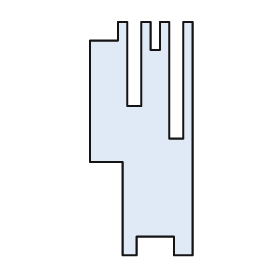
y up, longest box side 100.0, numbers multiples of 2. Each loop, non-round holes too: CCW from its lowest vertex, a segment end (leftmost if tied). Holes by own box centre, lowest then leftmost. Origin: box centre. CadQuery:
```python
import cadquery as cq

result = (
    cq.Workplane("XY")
    .moveTo(-8.0, -50.0)
    .lineTo(-2.0, -50.0)
    .lineTo(-2.0, -42.0)
    .lineTo(14.0, -42.0)
    .lineTo(14.0, -50.0)
    .lineTo(22.0, -50.0)
    .lineTo(22.0, 50.0)
    .lineTo(18.0, 50.0)
    .lineTo(18.0, 0.0)
    .lineTo(12.0, 0.0)
    .lineTo(12.0, 50.0)
    .lineTo(8.0, 50.0)
    .lineTo(8.0, 38.0)
    .lineTo(4.0, 38.0)
    .lineTo(4.0, 50.0)
    .lineTo(0.0, 50.0)
    .lineTo(0.0, 14.0)
    .lineTo(-6.0, 14.0)
    .lineTo(-6.0, 50.0)
    .lineTo(-10.0, 50.0)
    .lineTo(-10.0, 42.0)
    .lineTo(-22.0, 42.0)
    .lineTo(-22.0, -10.0)
    .lineTo(-8.0, -10.0)
    .close()
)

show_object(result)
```